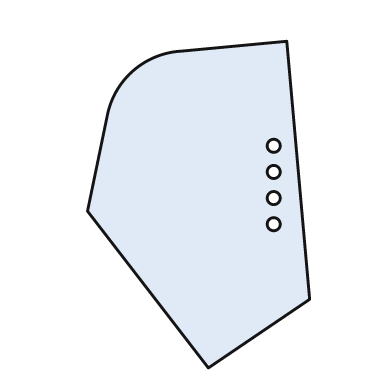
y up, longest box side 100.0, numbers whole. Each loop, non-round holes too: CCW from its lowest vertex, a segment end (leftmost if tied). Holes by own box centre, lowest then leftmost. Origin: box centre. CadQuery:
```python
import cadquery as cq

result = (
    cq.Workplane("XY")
    .moveTo(3.0, -50.0)
    .lineTo(34.0, -29.0)
    .lineTo(27.0, 50.0)
    .lineTo(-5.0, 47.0)
    .threePointArc((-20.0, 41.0), (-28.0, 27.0))
    .lineTo(-34.0, -2.0)
    .close()
    .moveTo(23.0, -6.0)
    .circle(2.0)
    .moveTo(23.0, 2.0)
    .circle(2.0)
    .moveTo(23.0, 10.0)
    .circle(2.0)
    .moveTo(23.0, 18.0)
    .circle(2.0)
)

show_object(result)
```